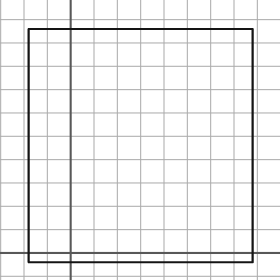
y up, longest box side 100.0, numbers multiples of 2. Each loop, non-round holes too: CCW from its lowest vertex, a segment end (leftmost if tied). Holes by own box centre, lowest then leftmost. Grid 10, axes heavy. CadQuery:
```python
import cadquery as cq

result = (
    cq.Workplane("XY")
    .moveTo(-18.0, -4.0)
    .lineTo(78.0, -4.0)
    .lineTo(78.0, 96.0)
    .lineTo(-18.0, 96.0)
    .close()
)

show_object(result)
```